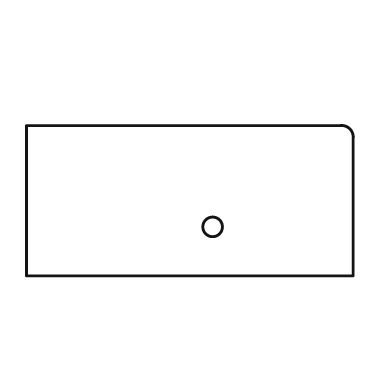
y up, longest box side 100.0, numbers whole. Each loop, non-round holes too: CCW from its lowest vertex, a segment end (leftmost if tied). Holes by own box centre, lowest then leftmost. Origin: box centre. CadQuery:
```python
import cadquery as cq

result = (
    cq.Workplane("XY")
    .moveTo(-50.0, -23.0)
    .lineTo(50.0, -23.0)
    .lineTo(50.0, 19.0)
    .threePointArc((49.0, 22.0), (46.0, 23.0))
    .lineTo(-50.0, 23.0)
    .close()
    .moveTo(7.0, -8.0)
    .circle(3.0)
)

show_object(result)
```